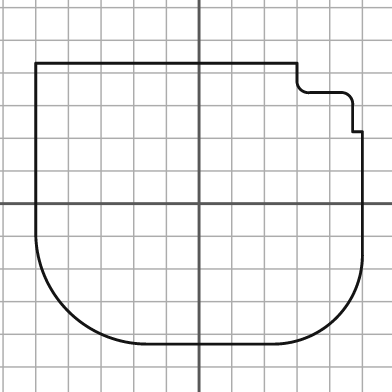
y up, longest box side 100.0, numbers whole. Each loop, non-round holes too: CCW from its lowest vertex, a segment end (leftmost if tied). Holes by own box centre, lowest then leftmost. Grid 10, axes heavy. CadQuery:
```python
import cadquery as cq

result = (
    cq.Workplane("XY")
    .moveTo(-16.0, -43.0)
    .lineTo(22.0, -43.0)
    .threePointArc((42.0, -35.0), (50.0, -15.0))
    .lineTo(50.0, 22.0)
    .lineTo(47.0, 22.0)
    .lineTo(47.0, 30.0)
    .threePointArc((46.0, 33.0), (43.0, 34.0))
    .lineTo(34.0, 34.0)
    .threePointArc((31.0, 35.0), (30.0, 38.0))
    .lineTo(30.0, 43.0)
    .lineTo(-50.0, 43.0)
    .lineTo(-50.0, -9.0)
    .threePointArc((-40.0, -33.0), (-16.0, -43.0))
    .close()
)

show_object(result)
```